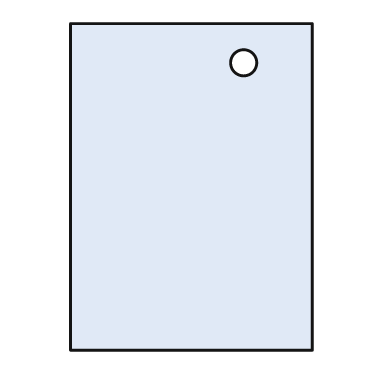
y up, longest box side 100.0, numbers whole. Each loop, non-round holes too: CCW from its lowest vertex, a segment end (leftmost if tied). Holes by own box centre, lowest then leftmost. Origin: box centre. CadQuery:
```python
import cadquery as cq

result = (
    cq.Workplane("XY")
    .moveTo(-37.0, -50.0)
    .lineTo(37.0, -50.0)
    .lineTo(37.0, 50.0)
    .lineTo(-37.0, 50.0)
    .close()
    .moveTo(16.0, 38.0)
    .circle(4.0)
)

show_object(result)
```